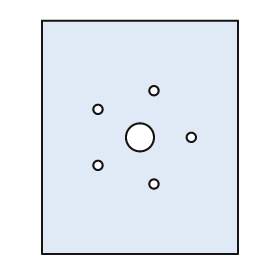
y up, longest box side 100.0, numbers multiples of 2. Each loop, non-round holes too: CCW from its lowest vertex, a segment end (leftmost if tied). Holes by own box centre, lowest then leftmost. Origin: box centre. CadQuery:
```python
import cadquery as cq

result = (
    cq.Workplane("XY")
    .moveTo(-42.0, -50.0)
    .lineTo(42.0, -50.0)
    .lineTo(42.0, 50.0)
    .lineTo(-42.0, 50.0)
    .close()
    .moveTo(6.0, -20.0)
    .circle(2.0)
    .moveTo(-18.0, -12.0)
    .circle(2.0)
    .moveTo(0.0, 0.0)
    .circle(6.0)
    .moveTo(22.0, 0.0)
    .circle(2.0)
    .moveTo(-18.0, 12.0)
    .circle(2.0)
    .moveTo(6.0, 20.0)
    .circle(2.0)
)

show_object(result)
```